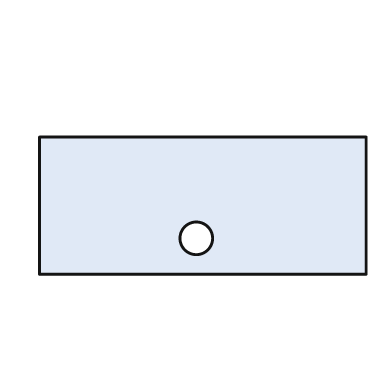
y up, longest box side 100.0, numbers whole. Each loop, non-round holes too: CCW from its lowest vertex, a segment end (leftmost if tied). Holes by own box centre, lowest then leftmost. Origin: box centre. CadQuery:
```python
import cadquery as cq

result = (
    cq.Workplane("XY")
    .moveTo(-50.0, -21.0)
    .lineTo(50.0, -21.0)
    .lineTo(50.0, 21.0)
    .lineTo(-50.0, 21.0)
    .close()
    .moveTo(-2.0, -10.0)
    .circle(5.0)
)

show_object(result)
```